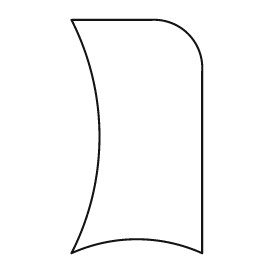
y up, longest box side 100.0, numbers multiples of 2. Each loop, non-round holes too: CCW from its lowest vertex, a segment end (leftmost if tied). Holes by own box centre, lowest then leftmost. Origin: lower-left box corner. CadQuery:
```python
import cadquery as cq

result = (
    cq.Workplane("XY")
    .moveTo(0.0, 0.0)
    .threePointArc((28.0, 6.0), (56.0, 0.0))
    .lineTo(56.0, 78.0)
    .threePointArc((50.0, 94.0), (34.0, 100.0))
    .lineTo(0.0, 100.0)
    .threePointArc((12.0, 50.0), (0.0, 0.0))
    .close()
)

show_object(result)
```